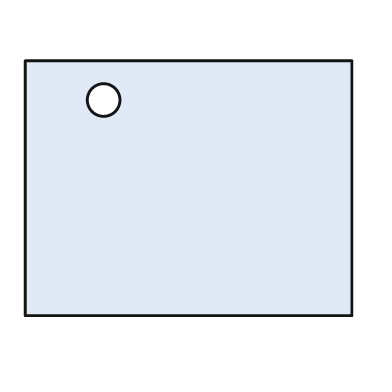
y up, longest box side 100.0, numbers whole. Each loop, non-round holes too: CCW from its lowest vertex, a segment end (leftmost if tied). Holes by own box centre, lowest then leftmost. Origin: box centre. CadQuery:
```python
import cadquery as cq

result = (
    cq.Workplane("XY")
    .moveTo(-50.0, -39.0)
    .lineTo(50.0, -39.0)
    .lineTo(50.0, 39.0)
    .lineTo(-50.0, 39.0)
    .close()
    .moveTo(-26.0, 27.0)
    .circle(5.0)
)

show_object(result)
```